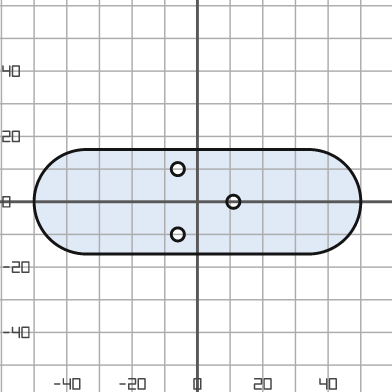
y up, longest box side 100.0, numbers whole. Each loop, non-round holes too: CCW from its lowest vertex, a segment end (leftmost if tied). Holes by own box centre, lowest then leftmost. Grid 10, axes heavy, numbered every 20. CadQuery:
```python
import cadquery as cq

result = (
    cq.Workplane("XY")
    .moveTo(-34.0, -16.0)
    .lineTo(34.0, -16.0)
    .threePointArc((50.0, 0.0), (34.0, 16.0))
    .lineTo(-34.0, 16.0)
    .threePointArc((-50.0, 0.0), (-34.0, -16.0))
    .close()
    .moveTo(-6.0, -10.0)
    .circle(2.0)
    .moveTo(11.0, 0.0)
    .circle(2.0)
    .moveTo(-6.0, 10.0)
    .circle(2.0)
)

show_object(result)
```